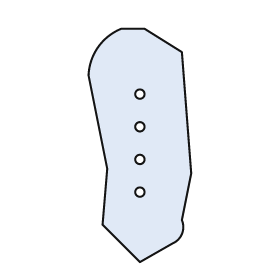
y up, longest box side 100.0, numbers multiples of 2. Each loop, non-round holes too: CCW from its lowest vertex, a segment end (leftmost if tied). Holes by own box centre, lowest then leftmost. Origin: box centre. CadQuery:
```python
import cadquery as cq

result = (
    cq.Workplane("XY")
    .moveTo(0.0, -50.0)
    .lineTo(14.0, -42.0)
    .threePointArc((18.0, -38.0), (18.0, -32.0))
    .lineTo(22.0, -12.0)
    .lineTo(18.0, 40.0)
    .lineTo(2.0, 50.0)
    .lineTo(-8.0, 50.0)
    .threePointArc((-18.0, 42.0), (-22.0, 30.0))
    .lineTo(-14.0, -10.0)
    .lineTo(-16.0, -34.0)
    .close()
    .moveTo(0.0, -20.0)
    .circle(2.0)
    .moveTo(0.0, -6.0)
    .circle(2.0)
    .moveTo(0.0, 8.0)
    .circle(2.0)
    .moveTo(0.0, 22.0)
    .circle(2.0)
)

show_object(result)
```